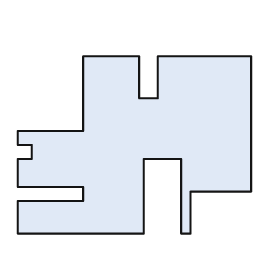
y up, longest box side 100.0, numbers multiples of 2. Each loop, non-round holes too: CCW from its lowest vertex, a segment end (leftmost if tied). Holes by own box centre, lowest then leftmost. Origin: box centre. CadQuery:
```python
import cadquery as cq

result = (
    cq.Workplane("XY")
    .moveTo(-50.0, -38.0)
    .lineTo(4.0, -38.0)
    .lineTo(4.0, -6.0)
    .lineTo(20.0, -6.0)
    .lineTo(20.0, -38.0)
    .lineTo(24.0, -38.0)
    .lineTo(24.0, -20.0)
    .lineTo(50.0, -20.0)
    .lineTo(50.0, 38.0)
    .lineTo(10.0, 38.0)
    .lineTo(10.0, 20.0)
    .lineTo(2.0, 20.0)
    .lineTo(2.0, 38.0)
    .lineTo(-22.0, 38.0)
    .lineTo(-22.0, 6.0)
    .lineTo(-50.0, 6.0)
    .lineTo(-50.0, 0.0)
    .lineTo(-44.0, 0.0)
    .lineTo(-44.0, -6.0)
    .lineTo(-50.0, -6.0)
    .lineTo(-50.0, -18.0)
    .lineTo(-22.0, -18.0)
    .lineTo(-22.0, -24.0)
    .lineTo(-50.0, -24.0)
    .close()
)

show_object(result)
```